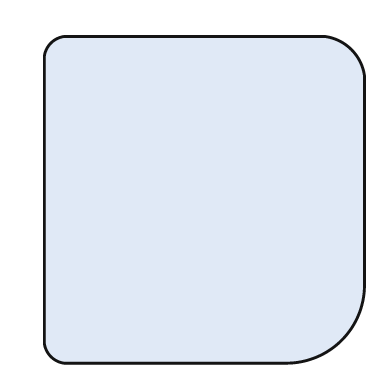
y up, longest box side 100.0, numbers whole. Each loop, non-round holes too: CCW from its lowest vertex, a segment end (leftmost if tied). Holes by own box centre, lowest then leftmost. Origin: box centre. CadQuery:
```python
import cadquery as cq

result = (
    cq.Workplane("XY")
    .moveTo(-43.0, -50.0)
    .lineTo(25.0, -50.0)
    .threePointArc((42.0, -43.0), (49.0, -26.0))
    .lineTo(49.0, 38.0)
    .threePointArc((45.0, 46.0), (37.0, 50.0))
    .lineTo(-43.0, 50.0)
    .threePointArc((-47.0, 48.0), (-49.0, 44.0))
    .lineTo(-49.0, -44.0)
    .threePointArc((-47.0, -48.0), (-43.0, -50.0))
    .close()
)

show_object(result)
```